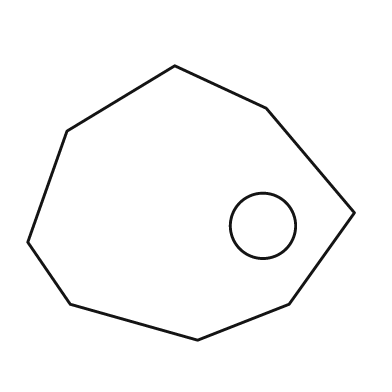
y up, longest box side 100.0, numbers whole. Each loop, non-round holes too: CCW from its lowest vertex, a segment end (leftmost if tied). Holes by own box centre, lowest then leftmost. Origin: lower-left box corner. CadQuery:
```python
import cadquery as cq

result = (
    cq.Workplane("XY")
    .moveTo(52.0, 0.0)
    .lineTo(80.0, 11.0)
    .lineTo(100.0, 39.0)
    .lineTo(73.0, 71.0)
    .lineTo(45.0, 84.0)
    .lineTo(12.0, 64.0)
    .lineTo(0.0, 30.0)
    .lineTo(13.0, 11.0)
    .close()
    .moveTo(72.0, 35.0)
    .circle(10.0)
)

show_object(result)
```